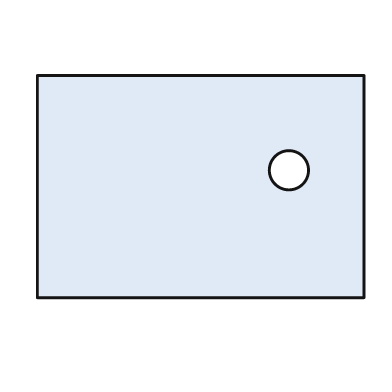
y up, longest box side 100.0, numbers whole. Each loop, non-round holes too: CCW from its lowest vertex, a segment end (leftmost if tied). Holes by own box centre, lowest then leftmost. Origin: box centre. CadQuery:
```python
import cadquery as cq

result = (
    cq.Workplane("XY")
    .moveTo(-50.0, -34.0)
    .lineTo(50.0, -34.0)
    .lineTo(50.0, 34.0)
    .lineTo(-50.0, 34.0)
    .close()
    .moveTo(27.0, 5.0)
    .circle(6.0)
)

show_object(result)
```